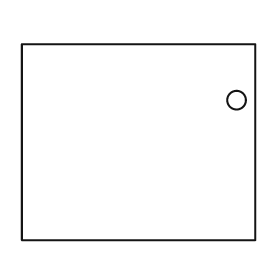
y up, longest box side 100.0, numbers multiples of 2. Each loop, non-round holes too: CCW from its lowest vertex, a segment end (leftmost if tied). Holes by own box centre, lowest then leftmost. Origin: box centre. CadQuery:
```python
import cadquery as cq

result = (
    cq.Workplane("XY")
    .moveTo(-50.0, -42.0)
    .lineTo(50.0, -42.0)
    .lineTo(50.0, 42.0)
    .lineTo(-50.0, 42.0)
    .close()
    .moveTo(42.0, 18.0)
    .circle(4.0)
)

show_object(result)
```